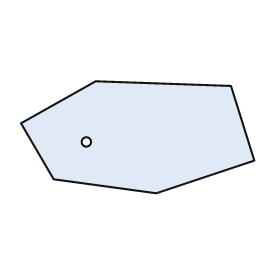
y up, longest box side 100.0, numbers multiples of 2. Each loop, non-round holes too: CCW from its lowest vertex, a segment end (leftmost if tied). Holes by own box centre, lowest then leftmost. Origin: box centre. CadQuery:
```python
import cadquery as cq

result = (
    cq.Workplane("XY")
    .moveTo(8.0, -24.0)
    .lineTo(50.0, -10.0)
    .lineTo(40.0, 22.0)
    .lineTo(-18.0, 24.0)
    .lineTo(-50.0, 6.0)
    .lineTo(-36.0, -18.0)
    .close()
    .moveTo(-22.0, -2.0)
    .circle(2.0)
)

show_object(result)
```